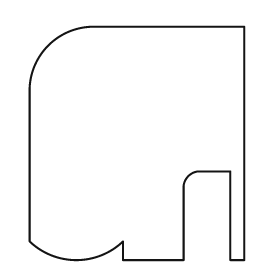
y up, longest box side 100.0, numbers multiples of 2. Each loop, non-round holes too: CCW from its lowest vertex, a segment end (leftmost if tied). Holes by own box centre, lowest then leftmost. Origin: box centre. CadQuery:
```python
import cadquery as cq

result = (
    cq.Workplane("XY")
    .moveTo(-6.0, -50.0)
    .lineTo(20.0, -50.0)
    .lineTo(20.0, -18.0)
    .threePointArc((22.0, -14.0), (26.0, -12.0))
    .lineTo(40.0, -12.0)
    .lineTo(40.0, -50.0)
    .lineTo(46.0, -50.0)
    .lineTo(46.0, 50.0)
    .lineTo(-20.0, 50.0)
    .threePointArc((-38.0, 42.0), (-46.0, 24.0))
    .lineTo(-46.0, -42.0)
    .threePointArc((-26.0, -50.0), (-6.0, -42.0))
    .close()
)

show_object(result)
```